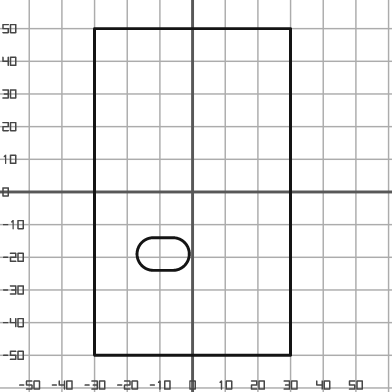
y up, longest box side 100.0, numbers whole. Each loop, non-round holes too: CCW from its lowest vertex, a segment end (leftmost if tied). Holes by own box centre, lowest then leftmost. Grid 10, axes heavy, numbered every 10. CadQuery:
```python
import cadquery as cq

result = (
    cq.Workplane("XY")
    .moveTo(-30.0, -50.0)
    .lineTo(30.0, -50.0)
    .lineTo(30.0, 50.0)
    .lineTo(-30.0, 50.0)
    .close()
    .moveTo(-12.0, -24.0)
    .lineTo(-6.0, -24.0)
    .threePointArc((-1.0, -19.0), (-6.0, -14.0))
    .lineTo(-12.0, -14.0)
    .threePointArc((-17.0, -19.0), (-12.0, -24.0))
    .close()
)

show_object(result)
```